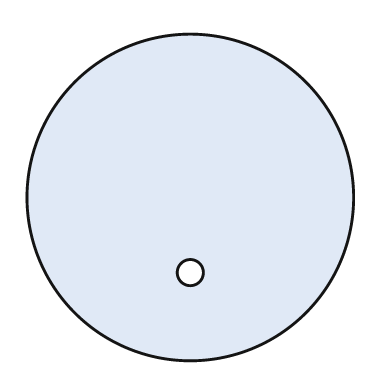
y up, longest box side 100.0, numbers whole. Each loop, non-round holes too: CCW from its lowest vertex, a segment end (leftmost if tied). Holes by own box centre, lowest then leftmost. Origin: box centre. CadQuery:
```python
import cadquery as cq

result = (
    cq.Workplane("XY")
    .moveTo(0.0, 0.0)
    .circle(50.0)
    .moveTo(0.0, -23.0)
    .circle(4.0)
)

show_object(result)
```